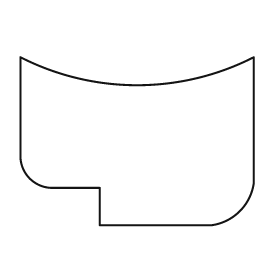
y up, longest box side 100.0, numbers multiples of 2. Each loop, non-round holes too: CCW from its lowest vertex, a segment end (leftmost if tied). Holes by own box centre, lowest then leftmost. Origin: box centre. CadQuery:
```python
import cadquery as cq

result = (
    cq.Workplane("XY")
    .moveTo(-16.0, -36.0)
    .lineTo(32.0, -36.0)
    .threePointArc((44.0, -30.0), (50.0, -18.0))
    .lineTo(50.0, 36.0)
    .threePointArc((0.0, 24.0), (-50.0, 36.0))
    .lineTo(-50.0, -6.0)
    .threePointArc((-46.0, -16.0), (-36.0, -20.0))
    .lineTo(-16.0, -20.0)
    .close()
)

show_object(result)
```